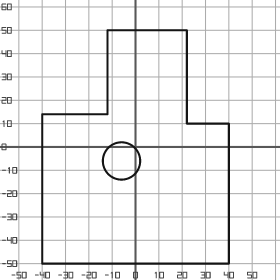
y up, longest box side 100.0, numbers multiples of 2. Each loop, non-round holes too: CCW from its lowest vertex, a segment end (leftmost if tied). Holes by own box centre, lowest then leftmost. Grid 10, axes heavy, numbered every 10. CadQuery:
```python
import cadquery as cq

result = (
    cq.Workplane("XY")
    .moveTo(-40.0, -50.0)
    .lineTo(40.0, -50.0)
    .lineTo(40.0, 10.0)
    .lineTo(22.0, 10.0)
    .lineTo(22.0, 50.0)
    .lineTo(-12.0, 50.0)
    .lineTo(-12.0, 14.0)
    .lineTo(-40.0, 14.0)
    .close()
    .moveTo(-6.0, -6.0)
    .circle(8.0)
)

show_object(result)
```